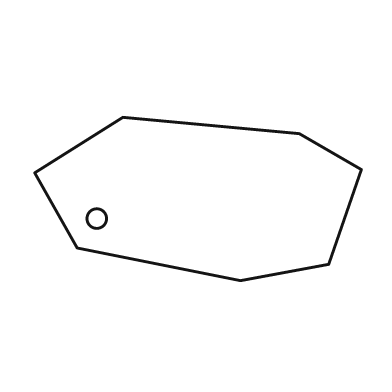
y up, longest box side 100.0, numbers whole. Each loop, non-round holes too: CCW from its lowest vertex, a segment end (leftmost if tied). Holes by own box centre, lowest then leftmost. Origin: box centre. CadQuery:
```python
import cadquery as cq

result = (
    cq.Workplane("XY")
    .moveTo(13.0, -25.0)
    .lineTo(40.0, -20.0)
    .lineTo(50.0, 9.0)
    .lineTo(31.0, 20.0)
    .lineTo(-23.0, 25.0)
    .lineTo(-50.0, 8.0)
    .lineTo(-37.0, -15.0)
    .close()
    .moveTo(-31.0, -6.0)
    .circle(3.0)
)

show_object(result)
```